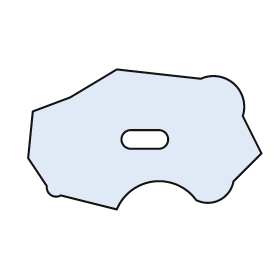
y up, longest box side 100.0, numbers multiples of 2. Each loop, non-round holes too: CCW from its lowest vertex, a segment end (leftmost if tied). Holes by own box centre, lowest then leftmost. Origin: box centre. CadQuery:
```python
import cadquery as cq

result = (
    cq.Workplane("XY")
    .moveTo(-12.0, -30.0)
    .threePointArc((4.0, -18.0), (22.0, -26.0))
    .threePointArc((32.0, -26.0), (38.0, -18.0))
    .lineTo(50.0, -6.0)
    .lineTo(42.0, 10.0)
    .threePointArc((38.0, 24.0), (24.0, 26.0))
    .lineTo(-12.0, 30.0)
    .lineTo(-32.0, 18.0)
    .lineTo(-48.0, 12.0)
    .lineTo(-50.0, -8.0)
    .lineTo(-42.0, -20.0)
    .threePointArc((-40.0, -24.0), (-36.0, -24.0))
    .close()
    .moveTo(-6.0, -4.0)
    .lineTo(6.0, -4.0)
    .threePointArc((10.0, 0.0), (6.0, 4.0))
    .lineTo(-6.0, 4.0)
    .threePointArc((-10.0, 0.0), (-6.0, -4.0))
    .close()
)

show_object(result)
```